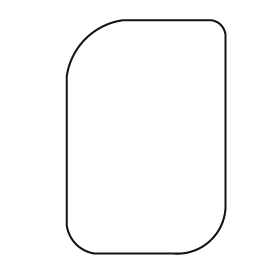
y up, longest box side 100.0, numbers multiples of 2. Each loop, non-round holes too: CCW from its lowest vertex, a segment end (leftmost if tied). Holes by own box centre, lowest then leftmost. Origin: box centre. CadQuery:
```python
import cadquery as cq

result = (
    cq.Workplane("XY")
    .moveTo(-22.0, -50.0)
    .lineTo(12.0, -50.0)
    .threePointArc((28.0, -44.0), (34.0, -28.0))
    .lineTo(34.0, 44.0)
    .threePointArc((32.0, 48.0), (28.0, 50.0))
    .lineTo(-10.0, 50.0)
    .threePointArc((-26.0, 42.0), (-34.0, 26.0))
    .lineTo(-34.0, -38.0)
    .threePointArc((-30.0, -46.0), (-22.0, -50.0))
    .close()
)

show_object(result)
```